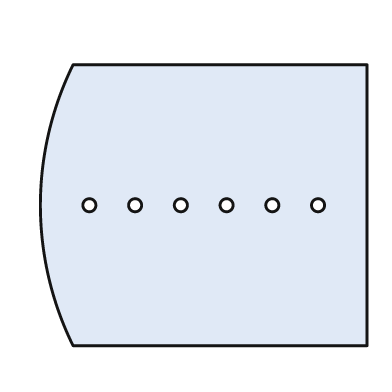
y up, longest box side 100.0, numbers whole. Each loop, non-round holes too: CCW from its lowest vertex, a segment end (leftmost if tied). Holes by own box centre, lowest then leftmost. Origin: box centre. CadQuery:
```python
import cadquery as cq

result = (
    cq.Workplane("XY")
    .moveTo(-40.0, -43.0)
    .lineTo(50.0, -43.0)
    .lineTo(50.0, 43.0)
    .lineTo(-40.0, 43.0)
    .threePointArc((-50.0, 0.0), (-40.0, -43.0))
    .close()
    .moveTo(-35.0, 0.0)
    .circle(2.0)
    .moveTo(-21.0, 0.0)
    .circle(2.0)
    .moveTo(-7.0, 0.0)
    .circle(2.0)
    .moveTo(7.0, 0.0)
    .circle(2.0)
    .moveTo(21.0, 0.0)
    .circle(2.0)
    .moveTo(35.0, 0.0)
    .circle(2.0)
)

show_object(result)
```